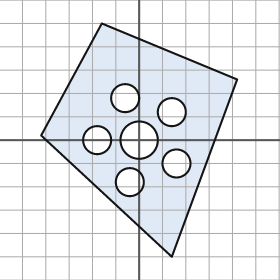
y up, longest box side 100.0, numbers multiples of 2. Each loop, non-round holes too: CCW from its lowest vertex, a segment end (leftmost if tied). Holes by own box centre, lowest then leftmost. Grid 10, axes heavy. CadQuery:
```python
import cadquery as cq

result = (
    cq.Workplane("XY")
    .moveTo(14.0, -50.0)
    .lineTo(42.0, 26.0)
    .lineTo(-16.0, 50.0)
    .lineTo(-42.0, 2.0)
    .close()
    .moveTo(-4.0, -18.0)
    .circle(6.0)
    .moveTo(16.0, -10.0)
    .circle(6.0)
    .moveTo(-18.0, 0.0)
    .circle(6.0)
    .moveTo(0.0, 0.0)
    .circle(8.0)
    .moveTo(14.0, 12.0)
    .circle(6.0)
    .moveTo(-6.0, 18.0)
    .circle(6.0)
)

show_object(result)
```